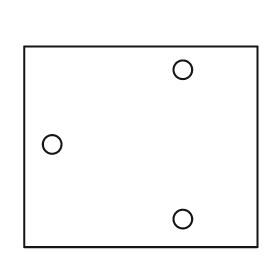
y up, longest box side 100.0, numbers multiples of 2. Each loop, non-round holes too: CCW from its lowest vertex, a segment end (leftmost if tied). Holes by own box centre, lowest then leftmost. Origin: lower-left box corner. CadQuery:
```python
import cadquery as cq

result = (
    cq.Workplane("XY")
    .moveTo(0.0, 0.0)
    .lineTo(100.0, 0.0)
    .lineTo(100.0, 86.0)
    .lineTo(0.0, 86.0)
    .close()
    .moveTo(68.0, 12.0)
    .circle(4.0)
    .moveTo(12.0, 44.0)
    .circle(4.0)
    .moveTo(68.0, 76.0)
    .circle(4.0)
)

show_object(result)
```